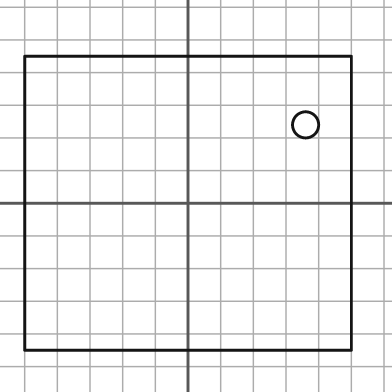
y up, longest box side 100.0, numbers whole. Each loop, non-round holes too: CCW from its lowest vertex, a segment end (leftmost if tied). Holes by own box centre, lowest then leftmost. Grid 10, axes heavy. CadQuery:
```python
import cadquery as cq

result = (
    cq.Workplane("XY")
    .moveTo(-50.0, -45.0)
    .lineTo(50.0, -45.0)
    .lineTo(50.0, 45.0)
    .lineTo(-50.0, 45.0)
    .close()
    .moveTo(36.0, 24.0)
    .circle(4.0)
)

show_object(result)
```